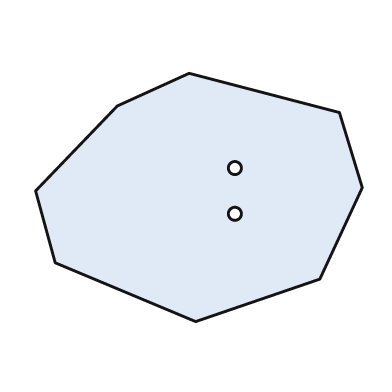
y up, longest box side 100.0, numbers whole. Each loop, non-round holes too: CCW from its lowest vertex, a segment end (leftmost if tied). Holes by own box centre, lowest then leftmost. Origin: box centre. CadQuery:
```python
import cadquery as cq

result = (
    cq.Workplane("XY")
    .moveTo(-1.0, -38.0)
    .lineTo(37.0, -25.0)
    .lineTo(50.0, 3.0)
    .lineTo(43.0, 26.0)
    .lineTo(-3.0, 38.0)
    .lineTo(-25.0, 28.0)
    .lineTo(-50.0, 2.0)
    .lineTo(-44.0, -20.0)
    .close()
    .moveTo(11.0, -5.0)
    .circle(2.0)
    .moveTo(11.0, 9.0)
    .circle(2.0)
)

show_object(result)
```